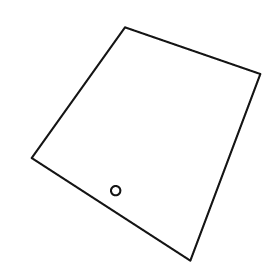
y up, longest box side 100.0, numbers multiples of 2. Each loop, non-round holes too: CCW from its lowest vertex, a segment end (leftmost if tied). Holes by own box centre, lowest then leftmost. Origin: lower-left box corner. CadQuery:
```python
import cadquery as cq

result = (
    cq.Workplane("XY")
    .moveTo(68.0, 0.0)
    .lineTo(98.0, 80.0)
    .lineTo(40.0, 100.0)
    .lineTo(0.0, 44.0)
    .close()
    .moveTo(36.0, 30.0)
    .circle(2.0)
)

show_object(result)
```